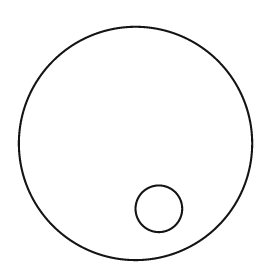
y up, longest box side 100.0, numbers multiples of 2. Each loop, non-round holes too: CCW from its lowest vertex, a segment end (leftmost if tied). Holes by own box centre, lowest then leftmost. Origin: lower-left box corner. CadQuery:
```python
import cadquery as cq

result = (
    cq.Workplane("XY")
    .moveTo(50.0, 50.0)
    .circle(50.0)
    .moveTo(60.0, 22.0)
    .circle(10.0)
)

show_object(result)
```